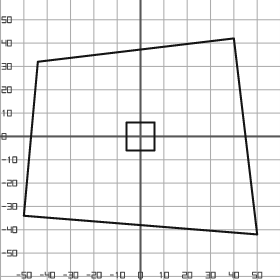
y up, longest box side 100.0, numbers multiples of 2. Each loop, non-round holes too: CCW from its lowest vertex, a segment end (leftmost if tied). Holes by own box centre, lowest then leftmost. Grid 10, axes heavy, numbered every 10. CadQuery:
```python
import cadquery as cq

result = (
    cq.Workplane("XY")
    .moveTo(50.0, -42.0)
    .lineTo(40.0, 42.0)
    .lineTo(-44.0, 32.0)
    .lineTo(-50.0, -34.0)
    .close()
    .moveTo(-6.0, -6.0)
    .lineTo(6.0, -6.0)
    .lineTo(6.0, 6.0)
    .lineTo(-6.0, 6.0)
    .close()
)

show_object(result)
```